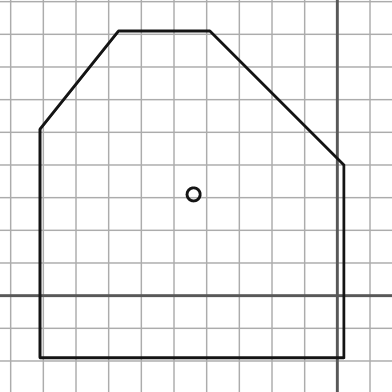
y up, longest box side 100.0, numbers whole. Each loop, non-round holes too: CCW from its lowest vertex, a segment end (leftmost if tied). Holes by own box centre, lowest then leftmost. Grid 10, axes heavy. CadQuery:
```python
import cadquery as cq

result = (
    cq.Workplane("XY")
    .moveTo(-91.0, -19.0)
    .lineTo(2.0, -19.0)
    .lineTo(2.0, 40.0)
    .lineTo(-39.0, 81.0)
    .lineTo(-67.0, 81.0)
    .lineTo(-91.0, 51.0)
    .close()
    .moveTo(-44.0, 31.0)
    .circle(2.0)
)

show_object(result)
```